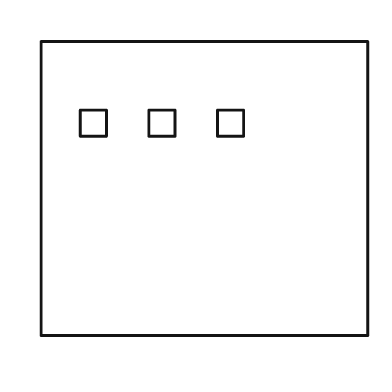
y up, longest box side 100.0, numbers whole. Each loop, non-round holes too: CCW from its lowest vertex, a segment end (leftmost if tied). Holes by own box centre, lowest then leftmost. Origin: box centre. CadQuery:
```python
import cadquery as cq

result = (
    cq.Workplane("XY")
    .moveTo(-50.0, -45.0)
    .lineTo(50.0, -45.0)
    .lineTo(50.0, 45.0)
    .lineTo(-50.0, 45.0)
    .close()
    .moveTo(-38.0, 16.0)
    .lineTo(-30.0, 16.0)
    .lineTo(-30.0, 24.0)
    .lineTo(-38.0, 24.0)
    .close()
    .moveTo(-17.0, 16.0)
    .lineTo(-9.0, 16.0)
    .lineTo(-9.0, 24.0)
    .lineTo(-17.0, 24.0)
    .close()
    .moveTo(4.0, 16.0)
    .lineTo(12.0, 16.0)
    .lineTo(12.0, 24.0)
    .lineTo(4.0, 24.0)
    .close()
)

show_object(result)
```